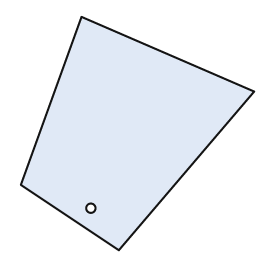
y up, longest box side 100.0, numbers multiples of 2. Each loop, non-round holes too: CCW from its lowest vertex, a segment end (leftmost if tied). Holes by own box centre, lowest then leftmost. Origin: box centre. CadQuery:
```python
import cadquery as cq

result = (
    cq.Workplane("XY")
    .moveTo(-8.0, -50.0)
    .lineTo(50.0, 18.0)
    .lineTo(-24.0, 50.0)
    .lineTo(-50.0, -22.0)
    .close()
    .moveTo(-20.0, -32.0)
    .circle(2.0)
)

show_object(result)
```